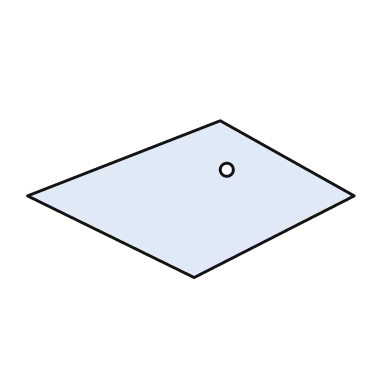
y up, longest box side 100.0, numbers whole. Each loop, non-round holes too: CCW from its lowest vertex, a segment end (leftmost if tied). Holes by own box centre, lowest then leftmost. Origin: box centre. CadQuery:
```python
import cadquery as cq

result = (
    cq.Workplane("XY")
    .moveTo(1.0, -24.0)
    .lineTo(50.0, 1.0)
    .lineTo(9.0, 24.0)
    .lineTo(-50.0, 1.0)
    .close()
    .moveTo(11.0, 9.0)
    .circle(2.0)
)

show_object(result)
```